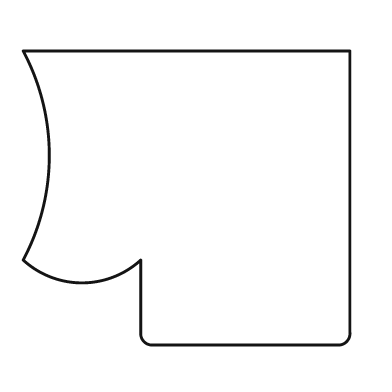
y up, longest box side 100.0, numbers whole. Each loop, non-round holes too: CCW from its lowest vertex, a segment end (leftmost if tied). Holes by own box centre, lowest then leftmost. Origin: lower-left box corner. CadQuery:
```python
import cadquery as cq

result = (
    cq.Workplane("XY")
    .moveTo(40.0, 0.0)
    .lineTo(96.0, 0.0)
    .threePointArc((99.0, 1.0), (100.0, 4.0))
    .lineTo(100.0, 90.0)
    .lineTo(0.0, 90.0)
    .threePointArc((8.0, 58.0), (0.0, 26.0))
    .threePointArc((18.0, 19.0), (36.0, 26.0))
    .lineTo(36.0, 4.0)
    .threePointArc((37.0, 1.0), (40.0, 0.0))
    .close()
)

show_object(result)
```